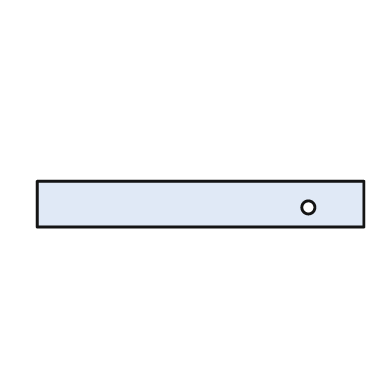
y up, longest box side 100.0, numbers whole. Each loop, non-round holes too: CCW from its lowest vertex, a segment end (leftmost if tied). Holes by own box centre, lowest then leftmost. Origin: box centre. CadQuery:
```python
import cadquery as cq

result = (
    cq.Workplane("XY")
    .moveTo(-50.0, -7.0)
    .lineTo(50.0, -7.0)
    .lineTo(50.0, 7.0)
    .lineTo(-50.0, 7.0)
    .close()
    .moveTo(33.0, -1.0)
    .circle(2.0)
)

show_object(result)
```